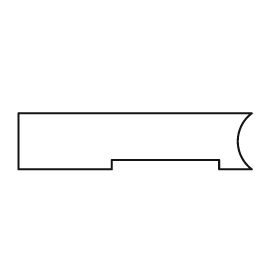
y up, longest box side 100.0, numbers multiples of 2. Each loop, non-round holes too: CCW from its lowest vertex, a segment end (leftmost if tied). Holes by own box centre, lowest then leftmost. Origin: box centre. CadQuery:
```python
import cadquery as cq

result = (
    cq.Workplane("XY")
    .moveTo(-50.0, -12.0)
    .lineTo(-10.0, -12.0)
    .lineTo(-10.0, -8.0)
    .lineTo(36.0, -8.0)
    .lineTo(36.0, -12.0)
    .lineTo(50.0, -12.0)
    .threePointArc((44.0, 0.0), (50.0, 12.0))
    .lineTo(-50.0, 12.0)
    .close()
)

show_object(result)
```